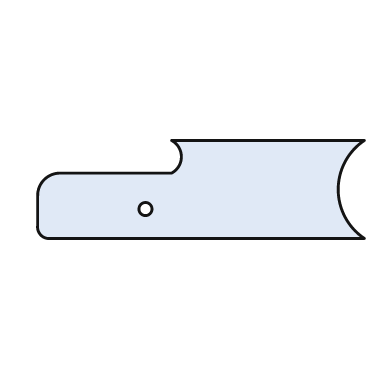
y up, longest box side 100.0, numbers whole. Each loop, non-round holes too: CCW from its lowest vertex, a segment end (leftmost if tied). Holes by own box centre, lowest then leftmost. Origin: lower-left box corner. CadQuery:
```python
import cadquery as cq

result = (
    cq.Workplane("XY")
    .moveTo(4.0, 0.0)
    .lineTo(100.0, 0.0)
    .threePointArc((92.0, 15.0), (100.0, 30.0))
    .lineTo(41.0, 30.0)
    .threePointArc((44.0, 25.0), (41.0, 20.0))
    .lineTo(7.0, 20.0)
    .threePointArc((2.0, 18.0), (0.0, 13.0))
    .lineTo(0.0, 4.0)
    .threePointArc((1.0, 1.0), (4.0, 0.0))
    .close()
    .moveTo(33.0, 9.0)
    .circle(2.0)
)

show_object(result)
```